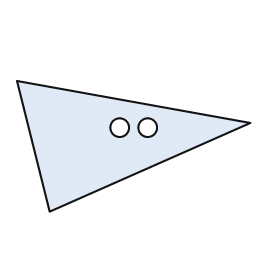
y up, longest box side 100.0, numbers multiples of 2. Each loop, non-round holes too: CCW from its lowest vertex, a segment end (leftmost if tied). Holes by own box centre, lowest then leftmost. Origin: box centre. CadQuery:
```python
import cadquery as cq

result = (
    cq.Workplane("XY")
    .moveTo(-36.0, -28.0)
    .lineTo(50.0, 10.0)
    .lineTo(-50.0, 28.0)
    .close()
    .moveTo(-6.0, 8.0)
    .circle(4.0)
    .moveTo(6.0, 8.0)
    .circle(4.0)
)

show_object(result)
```